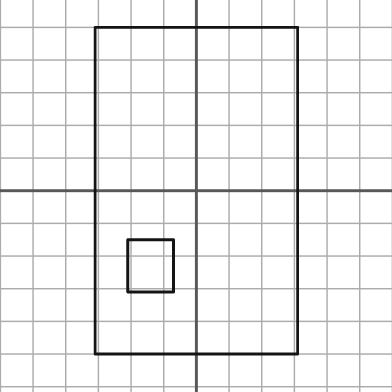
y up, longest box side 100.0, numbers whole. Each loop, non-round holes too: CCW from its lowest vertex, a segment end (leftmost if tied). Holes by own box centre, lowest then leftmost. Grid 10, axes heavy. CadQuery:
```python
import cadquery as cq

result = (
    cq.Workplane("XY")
    .moveTo(-31.0, -50.0)
    .lineTo(31.0, -50.0)
    .lineTo(31.0, 50.0)
    .lineTo(-31.0, 50.0)
    .close()
    .moveTo(-21.0, -31.0)
    .lineTo(-7.0, -31.0)
    .lineTo(-7.0, -15.0)
    .lineTo(-21.0, -15.0)
    .close()
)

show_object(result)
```